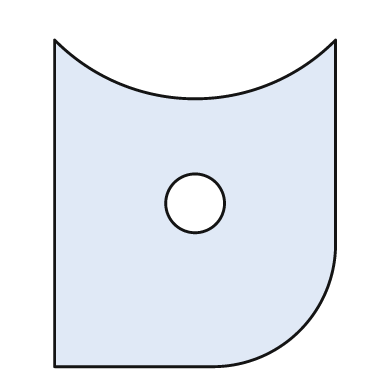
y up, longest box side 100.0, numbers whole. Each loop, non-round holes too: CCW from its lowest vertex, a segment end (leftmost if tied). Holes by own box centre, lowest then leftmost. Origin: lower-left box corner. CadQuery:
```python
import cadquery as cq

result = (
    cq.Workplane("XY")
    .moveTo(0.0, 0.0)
    .lineTo(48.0, 0.0)
    .threePointArc((75.0, 11.0), (86.0, 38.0))
    .lineTo(86.0, 100.0)
    .threePointArc((43.0, 82.0), (0.0, 100.0))
    .close()
    .moveTo(43.0, 50.0)
    .circle(9.0)
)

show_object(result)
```